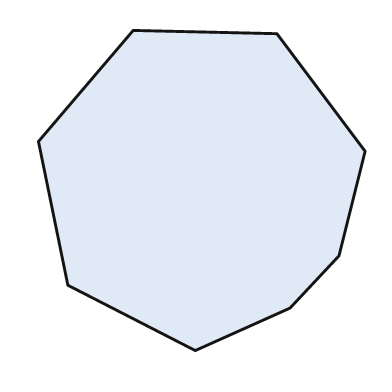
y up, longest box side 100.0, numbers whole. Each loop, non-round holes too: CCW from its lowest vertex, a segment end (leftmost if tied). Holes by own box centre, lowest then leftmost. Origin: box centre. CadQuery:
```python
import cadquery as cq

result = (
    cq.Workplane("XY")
    .moveTo(-2.0, -49.0)
    .lineTo(27.0, -36.0)
    .lineTo(42.0, -20.0)
    .lineTo(50.0, 12.0)
    .lineTo(23.0, 48.0)
    .lineTo(-21.0, 49.0)
    .lineTo(-50.0, 15.0)
    .lineTo(-41.0, -29.0)
    .close()
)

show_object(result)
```